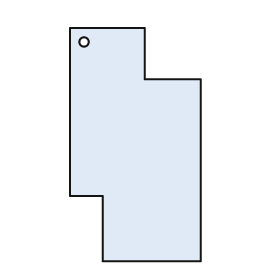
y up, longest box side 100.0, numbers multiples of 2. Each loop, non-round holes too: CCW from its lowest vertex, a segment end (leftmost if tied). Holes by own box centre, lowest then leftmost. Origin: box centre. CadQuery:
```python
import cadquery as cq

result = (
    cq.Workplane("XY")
    .moveTo(-14.0, -50.0)
    .lineTo(28.0, -50.0)
    .lineTo(28.0, 28.0)
    .lineTo(4.0, 28.0)
    .lineTo(4.0, 50.0)
    .lineTo(-28.0, 50.0)
    .lineTo(-28.0, -22.0)
    .lineTo(-14.0, -22.0)
    .close()
    .moveTo(-22.0, 44.0)
    .circle(2.0)
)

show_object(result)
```